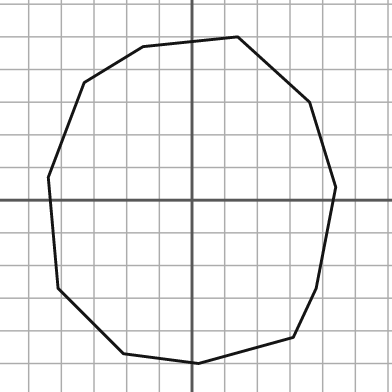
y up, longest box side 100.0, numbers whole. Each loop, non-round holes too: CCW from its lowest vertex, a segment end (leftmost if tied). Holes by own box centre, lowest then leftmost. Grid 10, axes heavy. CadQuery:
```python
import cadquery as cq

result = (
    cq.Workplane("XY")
    .moveTo(2.0, -50.0)
    .lineTo(31.0, -42.0)
    .lineTo(38.0, -27.0)
    .lineTo(44.0, 4.0)
    .lineTo(36.0, 30.0)
    .lineTo(14.0, 50.0)
    .lineTo(-15.0, 47.0)
    .lineTo(-33.0, 36.0)
    .lineTo(-44.0, 7.0)
    .lineTo(-41.0, -27.0)
    .lineTo(-21.0, -47.0)
    .close()
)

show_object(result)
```